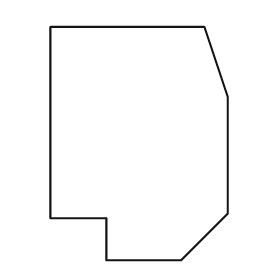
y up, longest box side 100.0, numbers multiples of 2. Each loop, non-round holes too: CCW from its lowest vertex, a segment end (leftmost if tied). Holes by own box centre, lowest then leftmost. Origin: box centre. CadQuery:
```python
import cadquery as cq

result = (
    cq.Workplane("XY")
    .moveTo(-14.0, -50.0)
    .lineTo(18.0, -50.0)
    .lineTo(38.0, -30.0)
    .lineTo(38.0, 20.0)
    .lineTo(28.0, 50.0)
    .lineTo(-38.0, 50.0)
    .lineTo(-38.0, -32.0)
    .lineTo(-14.0, -32.0)
    .close()
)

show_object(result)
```